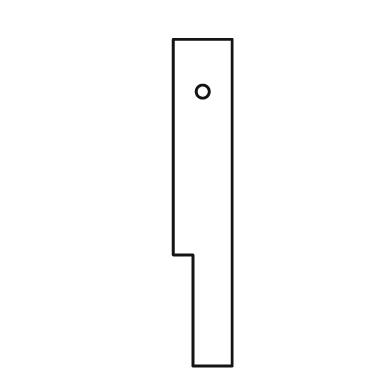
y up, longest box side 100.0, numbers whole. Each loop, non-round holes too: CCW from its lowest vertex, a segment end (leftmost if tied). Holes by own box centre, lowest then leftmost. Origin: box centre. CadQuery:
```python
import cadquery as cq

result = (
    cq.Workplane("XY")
    .moveTo(-3.0, -50.0)
    .lineTo(9.0, -50.0)
    .lineTo(9.0, 50.0)
    .lineTo(-9.0, 50.0)
    .lineTo(-9.0, -16.0)
    .lineTo(-3.0, -16.0)
    .close()
    .moveTo(0.0, 34.0)
    .circle(2.0)
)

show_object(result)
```